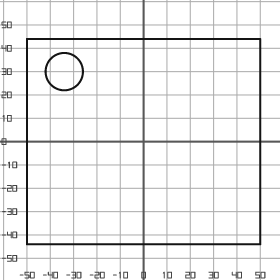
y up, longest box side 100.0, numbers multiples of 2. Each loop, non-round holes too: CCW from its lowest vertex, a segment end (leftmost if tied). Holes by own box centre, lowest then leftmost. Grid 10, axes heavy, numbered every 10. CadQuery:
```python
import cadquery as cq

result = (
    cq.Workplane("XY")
    .moveTo(-50.0, -44.0)
    .lineTo(50.0, -44.0)
    .lineTo(50.0, 44.0)
    .lineTo(-50.0, 44.0)
    .close()
    .moveTo(-34.0, 30.0)
    .circle(8.0)
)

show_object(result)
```